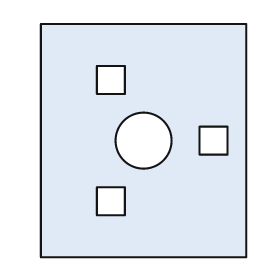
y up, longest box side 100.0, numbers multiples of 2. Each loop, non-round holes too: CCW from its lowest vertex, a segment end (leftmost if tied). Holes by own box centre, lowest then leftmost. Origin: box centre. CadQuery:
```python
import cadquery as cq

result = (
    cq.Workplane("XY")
    .moveTo(-44.0, -50.0)
    .lineTo(44.0, -50.0)
    .lineTo(44.0, 50.0)
    .lineTo(-44.0, 50.0)
    .close()
    .moveTo(-20.0, -32.0)
    .lineTo(-8.0, -32.0)
    .lineTo(-8.0, -20.0)
    .lineTo(-20.0, -20.0)
    .close()
    .moveTo(0.0, 0.0)
    .circle(12.0)
    .moveTo(24.0, -6.0)
    .lineTo(36.0, -6.0)
    .lineTo(36.0, 6.0)
    .lineTo(24.0, 6.0)
    .close()
    .moveTo(-20.0, 20.0)
    .lineTo(-8.0, 20.0)
    .lineTo(-8.0, 32.0)
    .lineTo(-20.0, 32.0)
    .close()
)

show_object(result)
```